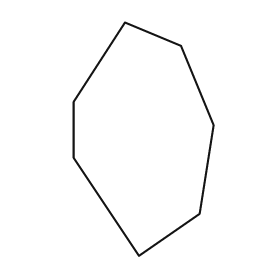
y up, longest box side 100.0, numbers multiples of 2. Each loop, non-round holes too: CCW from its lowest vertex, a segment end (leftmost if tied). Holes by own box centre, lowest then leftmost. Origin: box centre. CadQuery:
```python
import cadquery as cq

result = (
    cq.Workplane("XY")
    .moveTo(-2.0, -50.0)
    .lineTo(24.0, -32.0)
    .lineTo(30.0, 6.0)
    .lineTo(16.0, 40.0)
    .lineTo(-8.0, 50.0)
    .lineTo(-30.0, 16.0)
    .lineTo(-30.0, -8.0)
    .close()
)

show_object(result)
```